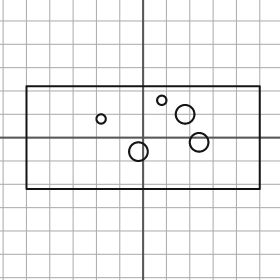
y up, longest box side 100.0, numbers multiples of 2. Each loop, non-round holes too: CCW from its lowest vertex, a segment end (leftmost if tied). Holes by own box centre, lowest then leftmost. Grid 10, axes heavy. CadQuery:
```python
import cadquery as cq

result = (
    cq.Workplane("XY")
    .moveTo(-50.0, -22.0)
    .lineTo(50.0, -22.0)
    .lineTo(50.0, 22.0)
    .lineTo(-50.0, 22.0)
    .close()
    .moveTo(-2.0, -6.0)
    .circle(4.0)
    .moveTo(24.0, -2.0)
    .circle(4.0)
    .moveTo(-18.0, 8.0)
    .circle(2.0)
    .moveTo(18.0, 10.0)
    .circle(4.0)
    .moveTo(8.0, 16.0)
    .circle(2.0)
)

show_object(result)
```